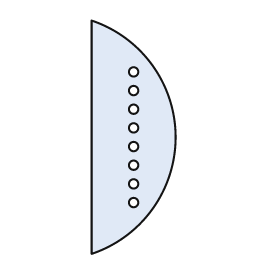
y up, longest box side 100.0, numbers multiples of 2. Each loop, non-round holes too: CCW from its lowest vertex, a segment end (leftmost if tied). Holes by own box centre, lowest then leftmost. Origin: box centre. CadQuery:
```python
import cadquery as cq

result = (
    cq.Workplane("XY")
    .moveTo(-18.0, -50.0)
    .threePointArc((18.0, 0.0), (-18.0, 50.0))
    .close()
    .moveTo(0.0, -28.0)
    .circle(2.0)
    .moveTo(0.0, -20.0)
    .circle(2.0)
    .moveTo(0.0, -12.0)
    .circle(2.0)
    .moveTo(0.0, -4.0)
    .circle(2.0)
    .moveTo(0.0, 4.0)
    .circle(2.0)
    .moveTo(0.0, 12.0)
    .circle(2.0)
    .moveTo(0.0, 20.0)
    .circle(2.0)
    .moveTo(0.0, 28.0)
    .circle(2.0)
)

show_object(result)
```